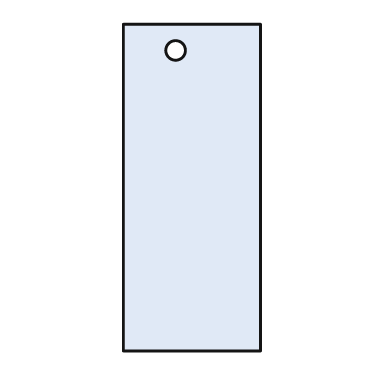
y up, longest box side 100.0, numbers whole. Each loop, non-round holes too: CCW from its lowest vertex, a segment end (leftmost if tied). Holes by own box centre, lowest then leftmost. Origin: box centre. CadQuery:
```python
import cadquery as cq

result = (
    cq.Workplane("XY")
    .moveTo(-21.0, -50.0)
    .lineTo(21.0, -50.0)
    .lineTo(21.0, 50.0)
    .lineTo(-21.0, 50.0)
    .close()
    .moveTo(-5.0, 42.0)
    .circle(3.0)
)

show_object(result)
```